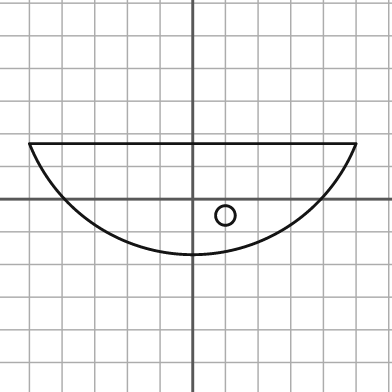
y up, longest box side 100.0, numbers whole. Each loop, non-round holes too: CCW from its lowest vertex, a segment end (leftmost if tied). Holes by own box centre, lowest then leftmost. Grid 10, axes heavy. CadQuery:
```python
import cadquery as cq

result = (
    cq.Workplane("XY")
    .moveTo(-50.0, 17.0)
    .threePointArc((0.0, -17.0), (50.0, 17.0))
    .close()
    .moveTo(10.0, -5.0)
    .circle(3.0)
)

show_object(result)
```